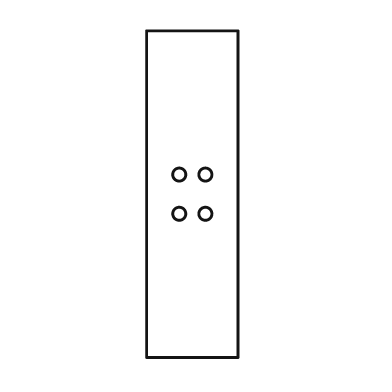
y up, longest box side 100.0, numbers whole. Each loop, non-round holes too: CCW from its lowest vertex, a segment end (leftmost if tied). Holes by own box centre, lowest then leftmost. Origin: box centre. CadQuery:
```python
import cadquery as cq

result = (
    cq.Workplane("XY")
    .moveTo(-14.0, -50.0)
    .lineTo(14.0, -50.0)
    .lineTo(14.0, 50.0)
    .lineTo(-14.0, 50.0)
    .close()
    .moveTo(-4.0, -6.0)
    .circle(2.0)
    .moveTo(4.0, -6.0)
    .circle(2.0)
    .moveTo(-4.0, 6.0)
    .circle(2.0)
    .moveTo(4.0, 6.0)
    .circle(2.0)
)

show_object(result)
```